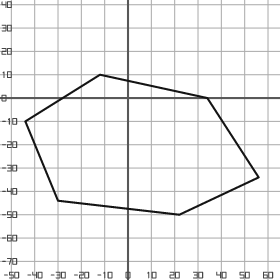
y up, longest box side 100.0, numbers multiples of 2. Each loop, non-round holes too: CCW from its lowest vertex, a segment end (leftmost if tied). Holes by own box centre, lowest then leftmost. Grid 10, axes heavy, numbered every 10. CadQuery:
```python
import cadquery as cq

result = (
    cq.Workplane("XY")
    .moveTo(22.0, -50.0)
    .lineTo(56.0, -34.0)
    .lineTo(34.0, 0.0)
    .lineTo(-12.0, 10.0)
    .lineTo(-44.0, -10.0)
    .lineTo(-30.0, -44.0)
    .close()
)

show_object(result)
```